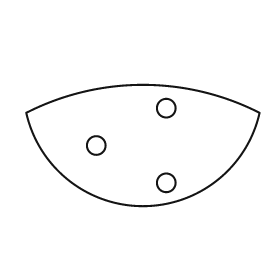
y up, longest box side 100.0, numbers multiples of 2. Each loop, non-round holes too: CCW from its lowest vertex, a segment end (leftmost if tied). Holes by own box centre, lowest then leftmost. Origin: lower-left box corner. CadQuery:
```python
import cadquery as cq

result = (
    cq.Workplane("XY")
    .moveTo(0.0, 40.0)
    .threePointArc((50.0, 0.0), (100.0, 40.0))
    .threePointArc((50.0, 52.0), (0.0, 40.0))
    .close()
    .moveTo(60.0, 10.0)
    .circle(4.0)
    .moveTo(30.0, 26.0)
    .circle(4.0)
    .moveTo(60.0, 42.0)
    .circle(4.0)
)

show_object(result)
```